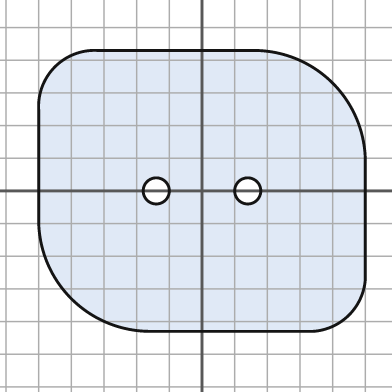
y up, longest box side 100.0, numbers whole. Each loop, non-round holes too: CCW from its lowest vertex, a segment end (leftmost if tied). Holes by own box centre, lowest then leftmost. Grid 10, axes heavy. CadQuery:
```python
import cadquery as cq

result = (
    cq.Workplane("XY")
    .moveTo(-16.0, -43.0)
    .lineTo(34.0, -43.0)
    .threePointArc((45.0, -38.0), (50.0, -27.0))
    .lineTo(50.0, 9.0)
    .threePointArc((40.0, 33.0), (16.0, 43.0))
    .lineTo(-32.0, 43.0)
    .threePointArc((-45.0, 38.0), (-50.0, 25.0))
    .lineTo(-50.0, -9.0)
    .threePointArc((-40.0, -33.0), (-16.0, -43.0))
    .close()
    .moveTo(-14.0, 0.0)
    .circle(4.0)
    .moveTo(14.0, 0.0)
    .circle(4.0)
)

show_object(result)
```